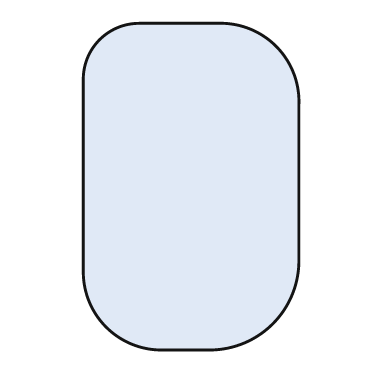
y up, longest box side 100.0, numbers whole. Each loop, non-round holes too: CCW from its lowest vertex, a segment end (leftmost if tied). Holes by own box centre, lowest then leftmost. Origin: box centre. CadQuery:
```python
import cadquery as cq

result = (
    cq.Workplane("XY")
    .moveTo(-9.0, -50.0)
    .lineTo(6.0, -50.0)
    .threePointArc((25.0, -42.0), (33.0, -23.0))
    .lineTo(33.0, 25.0)
    .threePointArc((26.0, 43.0), (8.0, 50.0))
    .lineTo(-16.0, 50.0)
    .threePointArc((-28.0, 45.0), (-33.0, 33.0))
    .lineTo(-33.0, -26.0)
    .threePointArc((-26.0, -43.0), (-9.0, -50.0))
    .close()
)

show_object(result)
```